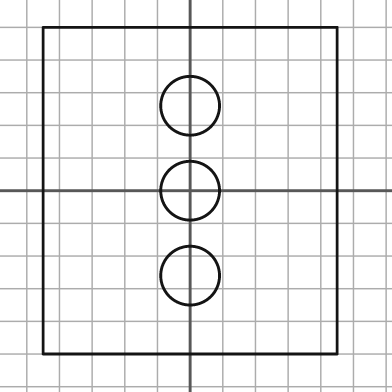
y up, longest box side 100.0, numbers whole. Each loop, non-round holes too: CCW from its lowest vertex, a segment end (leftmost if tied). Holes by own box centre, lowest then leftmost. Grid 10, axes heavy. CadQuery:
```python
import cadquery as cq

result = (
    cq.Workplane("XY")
    .moveTo(-45.0, -50.0)
    .lineTo(45.0, -50.0)
    .lineTo(45.0, 50.0)
    .lineTo(-45.0, 50.0)
    .close()
    .moveTo(0.0, -26.0)
    .circle(9.0)
    .moveTo(0.0, 0.0)
    .circle(9.0)
    .moveTo(0.0, 26.0)
    .circle(9.0)
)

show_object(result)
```